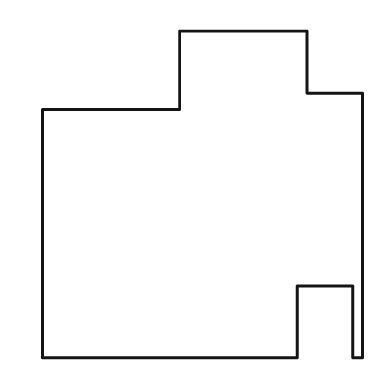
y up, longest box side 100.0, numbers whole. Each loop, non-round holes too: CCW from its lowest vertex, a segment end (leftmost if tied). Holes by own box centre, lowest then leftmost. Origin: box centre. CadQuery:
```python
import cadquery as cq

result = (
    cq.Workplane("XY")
    .moveTo(-49.0, -50.0)
    .lineTo(29.0, -50.0)
    .lineTo(29.0, -28.0)
    .lineTo(46.0, -28.0)
    .lineTo(46.0, -50.0)
    .lineTo(49.0, -50.0)
    .lineTo(49.0, 31.0)
    .lineTo(32.0, 31.0)
    .lineTo(32.0, 50.0)
    .lineTo(-7.0, 50.0)
    .lineTo(-7.0, 26.0)
    .lineTo(-49.0, 26.0)
    .close()
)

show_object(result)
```